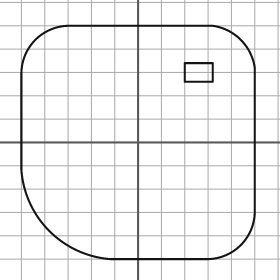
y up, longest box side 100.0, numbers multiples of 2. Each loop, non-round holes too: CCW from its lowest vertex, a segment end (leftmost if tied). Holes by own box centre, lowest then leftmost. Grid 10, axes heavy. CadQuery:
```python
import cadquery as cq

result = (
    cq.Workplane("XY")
    .moveTo(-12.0, -50.0)
    .lineTo(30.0, -50.0)
    .threePointArc((44.0, -44.0), (50.0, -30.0))
    .lineTo(50.0, 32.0)
    .threePointArc((44.0, 44.0), (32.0, 50.0))
    .lineTo(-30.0, 50.0)
    .threePointArc((-44.0, 44.0), (-50.0, 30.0))
    .lineTo(-50.0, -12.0)
    .threePointArc((-38.0, -38.0), (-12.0, -50.0))
    .close()
    .moveTo(20.0, 26.0)
    .lineTo(32.0, 26.0)
    .lineTo(32.0, 34.0)
    .lineTo(20.0, 34.0)
    .close()
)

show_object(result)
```